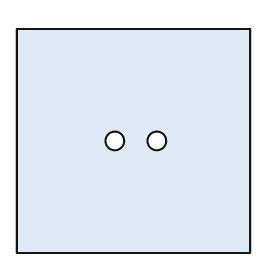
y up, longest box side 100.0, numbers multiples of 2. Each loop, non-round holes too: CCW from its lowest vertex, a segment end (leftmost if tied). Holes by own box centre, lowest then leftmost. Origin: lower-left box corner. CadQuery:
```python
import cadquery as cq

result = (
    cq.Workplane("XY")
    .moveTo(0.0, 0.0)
    .lineTo(100.0, 0.0)
    .lineTo(100.0, 96.0)
    .lineTo(0.0, 96.0)
    .close()
    .moveTo(42.0, 48.0)
    .circle(4.0)
    .moveTo(60.0, 48.0)
    .circle(4.0)
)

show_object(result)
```